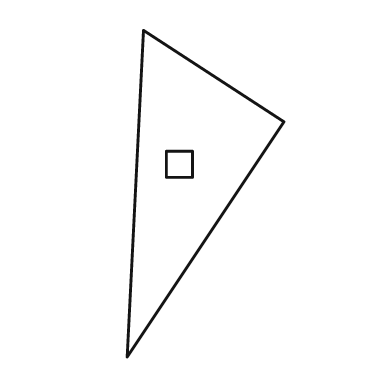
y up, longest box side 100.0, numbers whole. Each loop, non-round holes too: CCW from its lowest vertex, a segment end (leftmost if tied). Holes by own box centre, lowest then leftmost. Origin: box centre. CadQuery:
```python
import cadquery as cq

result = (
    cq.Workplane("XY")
    .moveTo(-24.0, -50.0)
    .lineTo(24.0, 22.0)
    .lineTo(-19.0, 50.0)
    .close()
    .moveTo(-12.0, 5.0)
    .lineTo(-4.0, 5.0)
    .lineTo(-4.0, 13.0)
    .lineTo(-12.0, 13.0)
    .close()
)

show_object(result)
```